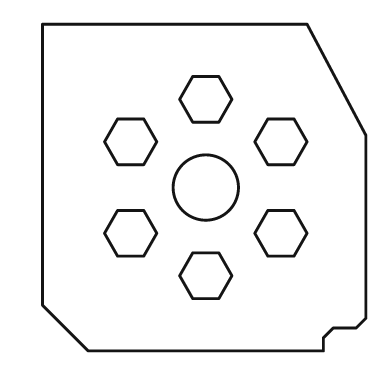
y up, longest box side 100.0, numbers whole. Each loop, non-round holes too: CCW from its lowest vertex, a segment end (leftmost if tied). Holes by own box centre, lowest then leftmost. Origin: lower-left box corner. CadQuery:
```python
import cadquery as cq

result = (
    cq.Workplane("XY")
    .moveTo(14.0, 0.0)
    .lineTo(86.0, 0.0)
    .lineTo(86.0, 4.0)
    .lineTo(89.0, 7.0)
    .lineTo(96.0, 7.0)
    .lineTo(99.0, 10.0)
    .lineTo(99.0, 66.0)
    .lineTo(81.0, 100.0)
    .lineTo(0.0, 100.0)
    .lineTo(0.0, 14.0)
    .close()
    .moveTo(46.0, 16.0)
    .lineTo(54.0, 16.0)
    .lineTo(58.0, 23.0)
    .lineTo(54.0, 30.0)
    .lineTo(46.0, 30.0)
    .lineTo(42.0, 23.0)
    .close()
    .moveTo(23.0, 29.0)
    .lineTo(31.0, 29.0)
    .lineTo(35.0, 36.0)
    .lineTo(31.0, 43.0)
    .lineTo(23.0, 43.0)
    .lineTo(19.0, 36.0)
    .close()
    .moveTo(69.0, 29.0)
    .lineTo(77.0, 29.0)
    .lineTo(81.0, 36.0)
    .lineTo(77.0, 43.0)
    .lineTo(69.0, 43.0)
    .lineTo(65.0, 36.0)
    .close()
    .moveTo(50.0, 50.0)
    .circle(10.0)
    .moveTo(23.0, 57.0)
    .lineTo(31.0, 57.0)
    .lineTo(35.0, 64.0)
    .lineTo(31.0, 71.0)
    .lineTo(23.0, 71.0)
    .lineTo(19.0, 64.0)
    .close()
    .moveTo(69.0, 57.0)
    .lineTo(77.0, 57.0)
    .lineTo(81.0, 64.0)
    .lineTo(77.0, 71.0)
    .lineTo(69.0, 71.0)
    .lineTo(65.0, 64.0)
    .close()
    .moveTo(46.0, 70.0)
    .lineTo(54.0, 70.0)
    .lineTo(58.0, 77.0)
    .lineTo(54.0, 84.0)
    .lineTo(46.0, 84.0)
    .lineTo(42.0, 77.0)
    .close()
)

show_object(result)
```